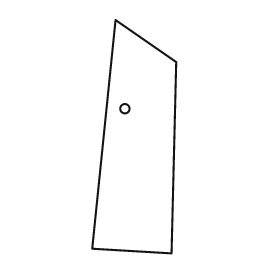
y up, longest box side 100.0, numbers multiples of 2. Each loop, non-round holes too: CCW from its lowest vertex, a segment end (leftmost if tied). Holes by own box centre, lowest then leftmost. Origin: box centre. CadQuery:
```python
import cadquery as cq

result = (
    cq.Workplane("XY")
    .moveTo(16.0, -50.0)
    .lineTo(18.0, 32.0)
    .lineTo(-8.0, 50.0)
    .lineTo(-18.0, -48.0)
    .close()
    .moveTo(-4.0, 12.0)
    .circle(2.0)
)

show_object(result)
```